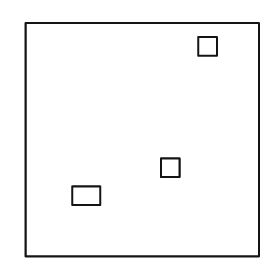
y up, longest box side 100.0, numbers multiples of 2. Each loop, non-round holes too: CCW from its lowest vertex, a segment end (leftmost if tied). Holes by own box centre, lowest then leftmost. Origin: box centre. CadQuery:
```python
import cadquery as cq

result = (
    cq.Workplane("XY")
    .moveTo(-50.0, -50.0)
    .lineTo(50.0, -50.0)
    .lineTo(50.0, 50.0)
    .lineTo(-50.0, 50.0)
    .close()
    .moveTo(-30.0, -28.0)
    .lineTo(-18.0, -28.0)
    .lineTo(-18.0, -20.0)
    .lineTo(-30.0, -20.0)
    .close()
    .moveTo(8.0, -16.0)
    .lineTo(16.0, -16.0)
    .lineTo(16.0, -8.0)
    .lineTo(8.0, -8.0)
    .close()
    .moveTo(24.0, 36.0)
    .lineTo(32.0, 36.0)
    .lineTo(32.0, 44.0)
    .lineTo(24.0, 44.0)
    .close()
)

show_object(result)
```